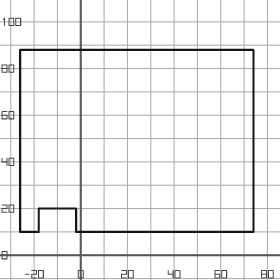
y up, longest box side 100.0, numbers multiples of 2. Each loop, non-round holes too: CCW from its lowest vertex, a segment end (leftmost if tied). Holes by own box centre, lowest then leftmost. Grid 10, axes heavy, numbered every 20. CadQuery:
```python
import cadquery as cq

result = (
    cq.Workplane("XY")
    .moveTo(-26.0, 10.0)
    .lineTo(-18.0, 10.0)
    .lineTo(-18.0, 20.0)
    .lineTo(-2.0, 20.0)
    .lineTo(-2.0, 10.0)
    .lineTo(74.0, 10.0)
    .lineTo(74.0, 88.0)
    .lineTo(-26.0, 88.0)
    .close()
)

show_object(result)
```